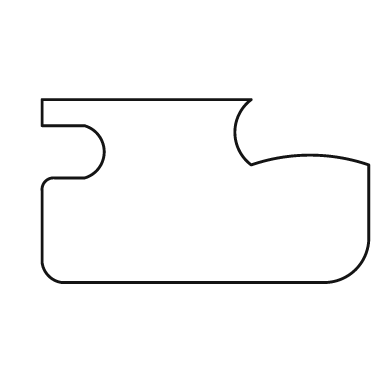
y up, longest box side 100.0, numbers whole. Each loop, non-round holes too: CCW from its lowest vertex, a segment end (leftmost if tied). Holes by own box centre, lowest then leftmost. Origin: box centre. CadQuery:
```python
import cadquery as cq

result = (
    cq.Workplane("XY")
    .moveTo(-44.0, -28.0)
    .lineTo(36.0, -28.0)
    .threePointArc((46.0, -24.0), (50.0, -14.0))
    .lineTo(50.0, 8.0)
    .threePointArc((32.0, 11.0), (14.0, 8.0))
    .threePointArc((9.0, 18.0), (14.0, 28.0))
    .lineTo(-50.0, 28.0)
    .lineTo(-50.0, 20.0)
    .lineTo(-37.0, 20.0)
    .threePointArc((-31.0, 12.0), (-37.0, 4.0))
    .lineTo(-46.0, 4.0)
    .threePointArc((-49.0, 3.0), (-50.0, 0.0))
    .lineTo(-50.0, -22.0)
    .threePointArc((-48.0, -26.0), (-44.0, -28.0))
    .close()
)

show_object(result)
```